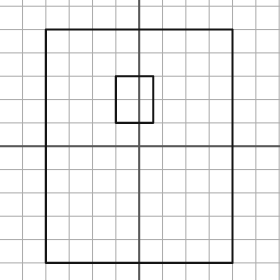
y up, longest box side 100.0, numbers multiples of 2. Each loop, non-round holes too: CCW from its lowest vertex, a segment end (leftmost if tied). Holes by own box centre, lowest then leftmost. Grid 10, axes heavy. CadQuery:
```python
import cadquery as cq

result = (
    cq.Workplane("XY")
    .moveTo(-40.0, -50.0)
    .lineTo(40.0, -50.0)
    .lineTo(40.0, 50.0)
    .lineTo(-40.0, 50.0)
    .close()
    .moveTo(-10.0, 10.0)
    .lineTo(6.0, 10.0)
    .lineTo(6.0, 30.0)
    .lineTo(-10.0, 30.0)
    .close()
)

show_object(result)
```